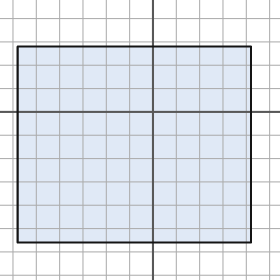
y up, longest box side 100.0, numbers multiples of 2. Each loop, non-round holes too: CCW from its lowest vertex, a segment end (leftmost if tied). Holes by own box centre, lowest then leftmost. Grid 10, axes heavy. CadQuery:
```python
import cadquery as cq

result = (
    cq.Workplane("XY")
    .moveTo(-58.0, -56.0)
    .lineTo(42.0, -56.0)
    .lineTo(42.0, 28.0)
    .lineTo(-58.0, 28.0)
    .close()
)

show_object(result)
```